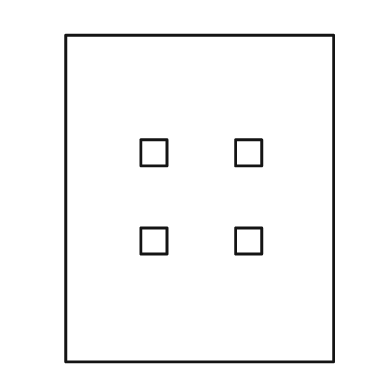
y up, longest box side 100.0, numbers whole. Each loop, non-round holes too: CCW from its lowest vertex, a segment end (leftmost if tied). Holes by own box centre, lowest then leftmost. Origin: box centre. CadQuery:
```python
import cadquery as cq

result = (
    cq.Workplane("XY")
    .moveTo(-41.0, -50.0)
    .lineTo(41.0, -50.0)
    .lineTo(41.0, 50.0)
    .lineTo(-41.0, 50.0)
    .close()
    .moveTo(-18.0, -17.0)
    .lineTo(-10.0, -17.0)
    .lineTo(-10.0, -9.0)
    .lineTo(-18.0, -9.0)
    .close()
    .moveTo(11.0, -17.0)
    .lineTo(19.0, -17.0)
    .lineTo(19.0, -9.0)
    .lineTo(11.0, -9.0)
    .close()
    .moveTo(-18.0, 10.0)
    .lineTo(-10.0, 10.0)
    .lineTo(-10.0, 18.0)
    .lineTo(-18.0, 18.0)
    .close()
    .moveTo(11.0, 10.0)
    .lineTo(19.0, 10.0)
    .lineTo(19.0, 18.0)
    .lineTo(11.0, 18.0)
    .close()
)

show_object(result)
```